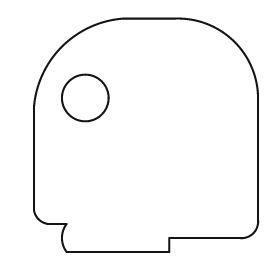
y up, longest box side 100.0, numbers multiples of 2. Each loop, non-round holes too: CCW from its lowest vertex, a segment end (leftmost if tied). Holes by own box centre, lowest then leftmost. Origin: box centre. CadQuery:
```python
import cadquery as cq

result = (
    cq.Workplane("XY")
    .moveTo(-34.0, -50.0)
    .lineTo(10.0, -50.0)
    .lineTo(10.0, -44.0)
    .lineTo(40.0, -44.0)
    .threePointArc((46.0, -42.0), (48.0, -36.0))
    .lineTo(48.0, 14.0)
    .threePointArc((38.0, 40.0), (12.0, 50.0))
    .lineTo(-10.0, 50.0)
    .threePointArc((-36.0, 38.0), (-48.0, 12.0))
    .lineTo(-48.0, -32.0)
    .threePointArc((-46.0, -36.0), (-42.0, -38.0))
    .lineTo(-34.0, -38.0)
    .threePointArc((-36.0, -44.0), (-34.0, -50.0))
    .close()
    .moveTo(-26.0, 16.0)
    .circle(10.0)
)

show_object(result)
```